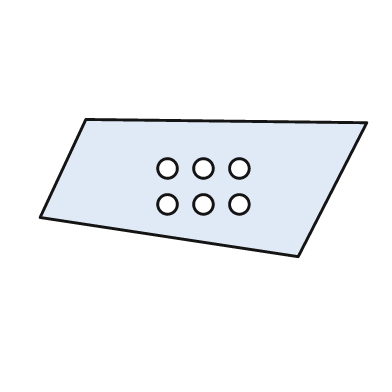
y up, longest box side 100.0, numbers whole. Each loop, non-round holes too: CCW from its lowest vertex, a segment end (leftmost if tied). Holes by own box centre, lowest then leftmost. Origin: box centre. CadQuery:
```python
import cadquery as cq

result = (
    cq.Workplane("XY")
    .moveTo(29.0, -21.0)
    .lineTo(50.0, 20.0)
    .lineTo(-36.0, 21.0)
    .lineTo(-50.0, -9.0)
    .close()
    .moveTo(-11.0, -5.0)
    .circle(3.0)
    .moveTo(0.0, -5.0)
    .circle(3.0)
    .moveTo(11.0, -5.0)
    .circle(3.0)
    .moveTo(-11.0, 6.0)
    .circle(3.0)
    .moveTo(0.0, 6.0)
    .circle(3.0)
    .moveTo(11.0, 6.0)
    .circle(3.0)
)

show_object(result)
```